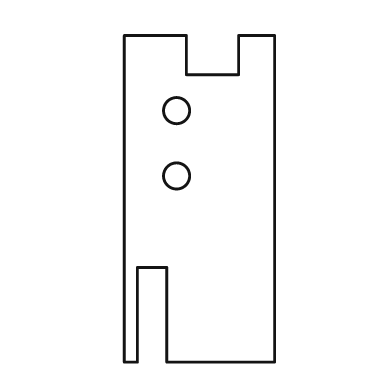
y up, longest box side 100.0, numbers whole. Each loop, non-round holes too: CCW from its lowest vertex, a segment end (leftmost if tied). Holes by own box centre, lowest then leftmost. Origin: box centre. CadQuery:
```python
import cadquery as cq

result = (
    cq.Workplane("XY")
    .moveTo(-23.0, -50.0)
    .lineTo(-19.0, -50.0)
    .lineTo(-19.0, -21.0)
    .lineTo(-10.0, -21.0)
    .lineTo(-10.0, -50.0)
    .lineTo(23.0, -50.0)
    .lineTo(23.0, 50.0)
    .lineTo(12.0, 50.0)
    .lineTo(12.0, 38.0)
    .lineTo(-4.0, 38.0)
    .lineTo(-4.0, 50.0)
    .lineTo(-23.0, 50.0)
    .close()
    .moveTo(-7.0, 7.0)
    .circle(4.0)
    .moveTo(-7.0, 27.0)
    .circle(4.0)
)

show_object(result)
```